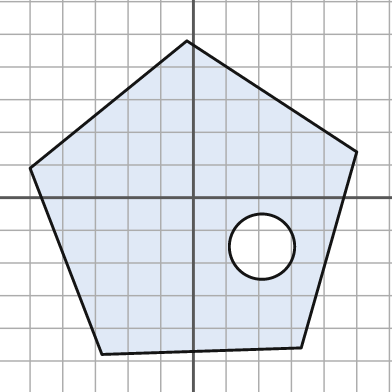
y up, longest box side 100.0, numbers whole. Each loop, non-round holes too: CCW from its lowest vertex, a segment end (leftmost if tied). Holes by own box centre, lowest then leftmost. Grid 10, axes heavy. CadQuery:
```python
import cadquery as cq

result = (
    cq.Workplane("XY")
    .moveTo(-28.0, -48.0)
    .lineTo(33.0, -46.0)
    .lineTo(50.0, 14.0)
    .lineTo(-2.0, 48.0)
    .lineTo(-50.0, 9.0)
    .close()
    .moveTo(21.0, -15.0)
    .circle(10.0)
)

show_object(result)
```